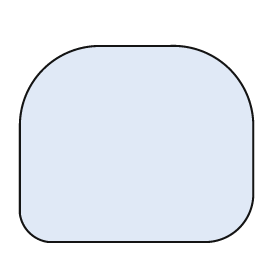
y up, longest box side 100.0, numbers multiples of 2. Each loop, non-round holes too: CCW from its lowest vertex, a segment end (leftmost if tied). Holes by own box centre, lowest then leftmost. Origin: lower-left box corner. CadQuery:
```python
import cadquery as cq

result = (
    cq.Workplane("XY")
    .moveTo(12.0, 0.0)
    .lineTo(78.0, 0.0)
    .threePointArc((94.0, 6.0), (100.0, 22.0))
    .lineTo(100.0, 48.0)
    .threePointArc((90.0, 74.0), (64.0, 84.0))
    .lineTo(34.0, 84.0)
    .threePointArc((10.0, 74.0), (0.0, 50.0))
    .lineTo(0.0, 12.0)
    .threePointArc((4.0, 4.0), (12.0, 0.0))
    .close()
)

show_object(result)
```